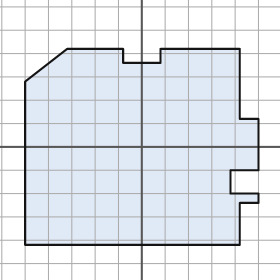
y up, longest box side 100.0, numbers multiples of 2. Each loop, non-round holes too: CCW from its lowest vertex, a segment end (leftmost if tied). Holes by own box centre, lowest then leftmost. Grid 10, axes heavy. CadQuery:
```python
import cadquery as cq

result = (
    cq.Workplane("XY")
    .moveTo(-50.0, -42.0)
    .lineTo(42.0, -42.0)
    .lineTo(42.0, -24.0)
    .lineTo(50.0, -24.0)
    .lineTo(50.0, -20.0)
    .lineTo(38.0, -20.0)
    .lineTo(38.0, -10.0)
    .lineTo(50.0, -10.0)
    .lineTo(50.0, 12.0)
    .lineTo(42.0, 12.0)
    .lineTo(42.0, 42.0)
    .lineTo(8.0, 42.0)
    .lineTo(8.0, 36.0)
    .lineTo(-8.0, 36.0)
    .lineTo(-8.0, 42.0)
    .lineTo(-32.0, 42.0)
    .lineTo(-50.0, 28.0)
    .close()
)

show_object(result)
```